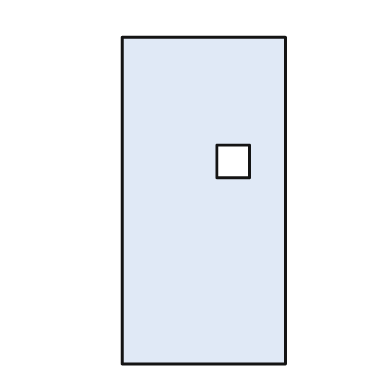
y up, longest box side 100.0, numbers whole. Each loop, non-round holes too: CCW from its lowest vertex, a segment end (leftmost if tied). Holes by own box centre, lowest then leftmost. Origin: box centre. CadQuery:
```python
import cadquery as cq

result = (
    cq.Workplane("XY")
    .moveTo(-25.0, -50.0)
    .lineTo(25.0, -50.0)
    .lineTo(25.0, 50.0)
    .lineTo(-25.0, 50.0)
    .close()
    .moveTo(4.0, 7.0)
    .lineTo(14.0, 7.0)
    .lineTo(14.0, 17.0)
    .lineTo(4.0, 17.0)
    .close()
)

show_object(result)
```